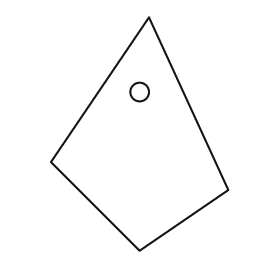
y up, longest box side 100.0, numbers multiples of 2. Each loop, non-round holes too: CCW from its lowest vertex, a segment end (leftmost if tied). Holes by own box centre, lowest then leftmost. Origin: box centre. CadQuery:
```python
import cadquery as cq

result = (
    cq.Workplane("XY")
    .moveTo(0.0, -50.0)
    .lineTo(38.0, -24.0)
    .lineTo(4.0, 50.0)
    .lineTo(-38.0, -12.0)
    .close()
    .moveTo(0.0, 18.0)
    .circle(4.0)
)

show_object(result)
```